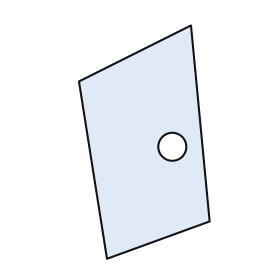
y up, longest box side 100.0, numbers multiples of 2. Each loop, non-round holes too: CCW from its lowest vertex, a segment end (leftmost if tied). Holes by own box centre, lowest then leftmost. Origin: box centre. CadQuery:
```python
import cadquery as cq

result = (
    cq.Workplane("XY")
    .moveTo(-16.0, -50.0)
    .lineTo(28.0, -34.0)
    .lineTo(20.0, 50.0)
    .lineTo(-28.0, 26.0)
    .close()
    .moveTo(12.0, -2.0)
    .circle(6.0)
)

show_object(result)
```